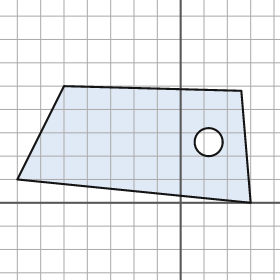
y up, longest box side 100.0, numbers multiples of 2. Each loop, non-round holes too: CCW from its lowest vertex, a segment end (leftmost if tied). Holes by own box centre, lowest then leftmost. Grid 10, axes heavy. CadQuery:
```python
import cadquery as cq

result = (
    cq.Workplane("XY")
    .moveTo(30.0, 0.0)
    .lineTo(26.0, 48.0)
    .lineTo(-50.0, 50.0)
    .lineTo(-70.0, 10.0)
    .close()
    .moveTo(12.0, 26.0)
    .circle(6.0)
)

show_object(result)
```